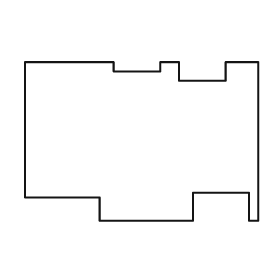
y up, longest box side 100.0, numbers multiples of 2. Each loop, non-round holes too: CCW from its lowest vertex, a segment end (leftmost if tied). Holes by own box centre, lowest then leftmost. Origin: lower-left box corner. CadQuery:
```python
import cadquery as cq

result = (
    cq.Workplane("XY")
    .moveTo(32.0, 0.0)
    .lineTo(72.0, 0.0)
    .lineTo(72.0, 12.0)
    .lineTo(96.0, 12.0)
    .lineTo(96.0, 0.0)
    .lineTo(100.0, 0.0)
    .lineTo(100.0, 68.0)
    .lineTo(86.0, 68.0)
    .lineTo(86.0, 60.0)
    .lineTo(66.0, 60.0)
    .lineTo(66.0, 68.0)
    .lineTo(58.0, 68.0)
    .lineTo(58.0, 64.0)
    .lineTo(38.0, 64.0)
    .lineTo(38.0, 68.0)
    .lineTo(0.0, 68.0)
    .lineTo(0.0, 10.0)
    .lineTo(32.0, 10.0)
    .close()
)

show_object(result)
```